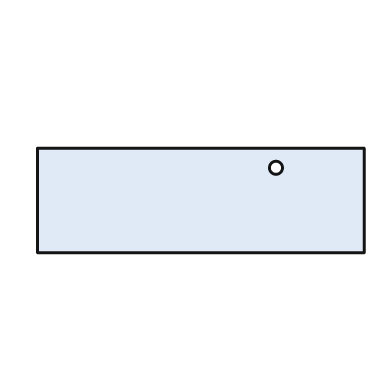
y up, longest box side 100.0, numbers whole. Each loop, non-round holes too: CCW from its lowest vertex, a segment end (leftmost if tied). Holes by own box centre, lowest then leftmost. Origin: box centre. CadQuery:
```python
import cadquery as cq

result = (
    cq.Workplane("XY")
    .moveTo(-50.0, -16.0)
    .lineTo(50.0, -16.0)
    .lineTo(50.0, 16.0)
    .lineTo(-50.0, 16.0)
    .close()
    .moveTo(23.0, 10.0)
    .circle(2.0)
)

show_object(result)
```